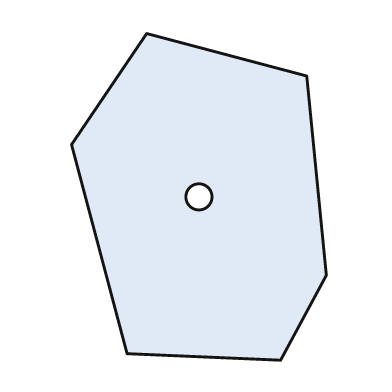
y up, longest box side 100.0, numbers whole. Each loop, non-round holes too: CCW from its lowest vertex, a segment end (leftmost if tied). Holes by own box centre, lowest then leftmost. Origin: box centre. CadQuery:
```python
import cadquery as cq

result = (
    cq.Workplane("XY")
    .moveTo(25.0, -50.0)
    .lineTo(39.0, -24.0)
    .lineTo(33.0, 37.0)
    .lineTo(-16.0, 50.0)
    .lineTo(-39.0, 16.0)
    .lineTo(-22.0, -48.0)
    .close()
    .moveTo(0.0, 0.0)
    .circle(4.0)
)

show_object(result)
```